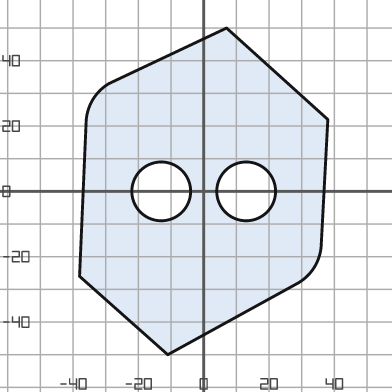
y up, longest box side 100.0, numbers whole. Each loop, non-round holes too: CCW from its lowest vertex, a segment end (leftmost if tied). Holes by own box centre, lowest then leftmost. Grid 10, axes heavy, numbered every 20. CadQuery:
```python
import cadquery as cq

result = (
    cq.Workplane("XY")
    .moveTo(-11.0, -50.0)
    .lineTo(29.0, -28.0)
    .threePointArc((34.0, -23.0), (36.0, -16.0))
    .lineTo(38.0, 22.0)
    .lineTo(7.0, 50.0)
    .lineTo(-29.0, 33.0)
    .threePointArc((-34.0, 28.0), (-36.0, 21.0))
    .lineTo(-38.0, -26.0)
    .close()
    .moveTo(-13.0, 0.0)
    .circle(9.0)
    .moveTo(13.0, 0.0)
    .circle(9.0)
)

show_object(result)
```